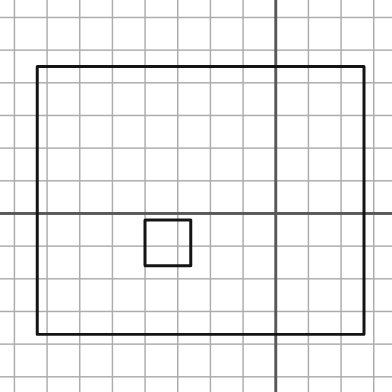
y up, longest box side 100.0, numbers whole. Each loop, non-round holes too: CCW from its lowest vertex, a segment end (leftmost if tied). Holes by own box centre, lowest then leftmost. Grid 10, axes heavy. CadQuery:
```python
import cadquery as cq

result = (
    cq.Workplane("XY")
    .moveTo(-73.0, -37.0)
    .lineTo(27.0, -37.0)
    .lineTo(27.0, 45.0)
    .lineTo(-73.0, 45.0)
    .close()
    .moveTo(-40.0, -16.0)
    .lineTo(-26.0, -16.0)
    .lineTo(-26.0, -2.0)
    .lineTo(-40.0, -2.0)
    .close()
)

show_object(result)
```